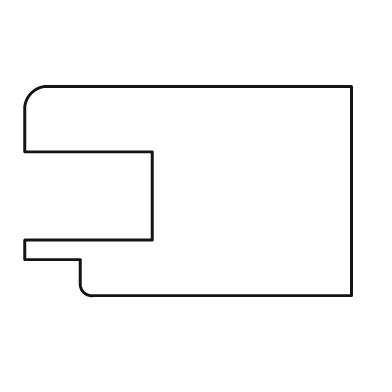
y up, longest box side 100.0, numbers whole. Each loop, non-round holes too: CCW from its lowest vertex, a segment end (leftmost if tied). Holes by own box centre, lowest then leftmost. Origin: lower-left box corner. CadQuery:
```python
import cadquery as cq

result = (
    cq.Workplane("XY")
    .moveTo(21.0, 0.0)
    .lineTo(100.0, 0.0)
    .lineTo(100.0, 64.0)
    .lineTo(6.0, 64.0)
    .threePointArc((2.0, 62.0), (0.0, 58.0))
    .lineTo(0.0, 44.0)
    .lineTo(39.0, 44.0)
    .lineTo(39.0, 17.0)
    .lineTo(0.0, 17.0)
    .lineTo(0.0, 11.0)
    .lineTo(17.0, 11.0)
    .lineTo(17.0, 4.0)
    .threePointArc((18.0, 1.0), (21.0, 0.0))
    .close()
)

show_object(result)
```